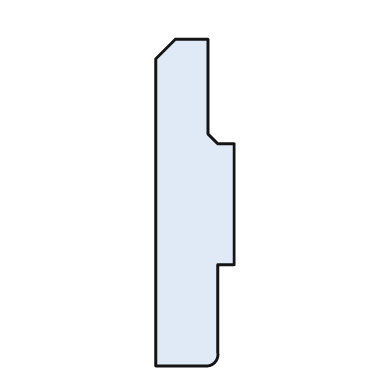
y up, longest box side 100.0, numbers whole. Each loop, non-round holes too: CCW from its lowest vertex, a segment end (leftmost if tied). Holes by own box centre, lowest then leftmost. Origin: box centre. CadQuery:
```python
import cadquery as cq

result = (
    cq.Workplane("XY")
    .moveTo(-12.0, -50.0)
    .lineTo(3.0, -50.0)
    .threePointArc((6.0, -49.0), (7.0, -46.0))
    .lineTo(7.0, -19.0)
    .lineTo(12.0, -19.0)
    .lineTo(12.0, 18.0)
    .lineTo(7.0, 18.0)
    .lineTo(4.0, 21.0)
    .lineTo(4.0, 50.0)
    .lineTo(-6.0, 50.0)
    .lineTo(-12.0, 44.0)
    .close()
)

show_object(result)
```